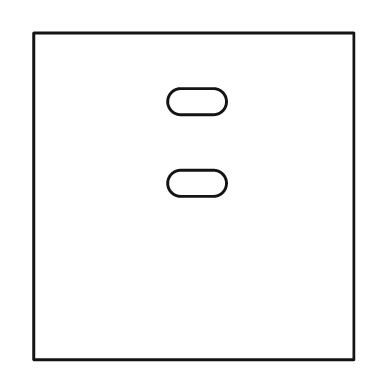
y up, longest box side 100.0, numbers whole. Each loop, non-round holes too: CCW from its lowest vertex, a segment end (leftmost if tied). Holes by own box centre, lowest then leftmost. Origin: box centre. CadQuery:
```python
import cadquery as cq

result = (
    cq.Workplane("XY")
    .moveTo(-49.0, -50.0)
    .lineTo(49.0, -50.0)
    .lineTo(49.0, 50.0)
    .lineTo(-49.0, 50.0)
    .close()
    .moveTo(-4.0, 0.0)
    .lineTo(6.0, 0.0)
    .threePointArc((10.0, 4.0), (6.0, 8.0))
    .lineTo(-4.0, 8.0)
    .threePointArc((-8.0, 4.0), (-4.0, 0.0))
    .close()
    .moveTo(-4.0, 25.0)
    .lineTo(6.0, 25.0)
    .threePointArc((10.0, 29.0), (6.0, 33.0))
    .lineTo(-4.0, 33.0)
    .threePointArc((-8.0, 29.0), (-4.0, 25.0))
    .close()
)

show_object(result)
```